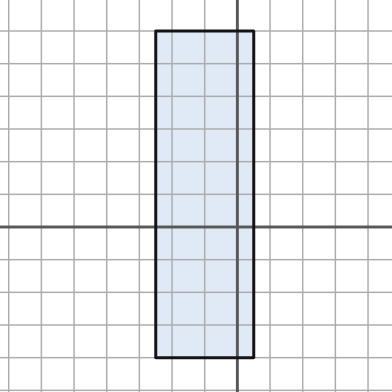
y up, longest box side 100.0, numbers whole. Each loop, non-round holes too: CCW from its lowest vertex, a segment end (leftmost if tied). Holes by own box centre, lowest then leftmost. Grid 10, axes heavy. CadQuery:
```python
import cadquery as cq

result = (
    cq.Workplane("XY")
    .moveTo(-25.0, -40.0)
    .lineTo(5.0, -40.0)
    .lineTo(5.0, 60.0)
    .lineTo(-25.0, 60.0)
    .close()
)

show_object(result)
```